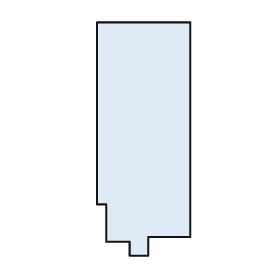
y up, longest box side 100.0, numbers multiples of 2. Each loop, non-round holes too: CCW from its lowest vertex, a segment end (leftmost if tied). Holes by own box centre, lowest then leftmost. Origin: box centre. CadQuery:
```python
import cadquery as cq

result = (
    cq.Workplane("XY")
    .moveTo(-6.0, -50.0)
    .lineTo(2.0, -50.0)
    .lineTo(2.0, -42.0)
    .lineTo(20.0, -42.0)
    .lineTo(20.0, 50.0)
    .lineTo(-20.0, 50.0)
    .lineTo(-20.0, -28.0)
    .lineTo(-16.0, -28.0)
    .lineTo(-16.0, -44.0)
    .lineTo(-6.0, -44.0)
    .close()
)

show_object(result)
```